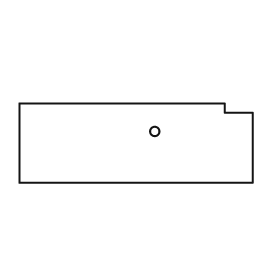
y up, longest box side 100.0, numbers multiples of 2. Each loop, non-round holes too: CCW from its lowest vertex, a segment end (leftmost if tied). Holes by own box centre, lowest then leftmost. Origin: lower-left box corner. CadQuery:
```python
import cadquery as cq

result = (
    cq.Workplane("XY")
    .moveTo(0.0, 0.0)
    .lineTo(100.0, 0.0)
    .lineTo(100.0, 30.0)
    .lineTo(88.0, 30.0)
    .lineTo(88.0, 34.0)
    .lineTo(0.0, 34.0)
    .close()
    .moveTo(58.0, 22.0)
    .circle(2.0)
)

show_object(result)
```